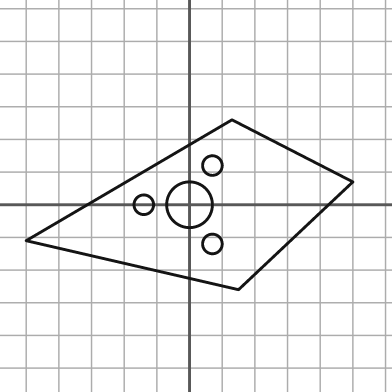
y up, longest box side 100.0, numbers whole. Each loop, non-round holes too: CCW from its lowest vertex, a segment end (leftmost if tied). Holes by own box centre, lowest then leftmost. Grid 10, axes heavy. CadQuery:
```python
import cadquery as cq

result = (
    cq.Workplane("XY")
    .moveTo(15.0, -26.0)
    .lineTo(50.0, 7.0)
    .lineTo(13.0, 26.0)
    .lineTo(-50.0, -11.0)
    .close()
    .moveTo(7.0, -12.0)
    .circle(3.0)
    .moveTo(-14.0, 0.0)
    .circle(3.0)
    .moveTo(0.0, 0.0)
    .circle(7.0)
    .moveTo(7.0, 12.0)
    .circle(3.0)
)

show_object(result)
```